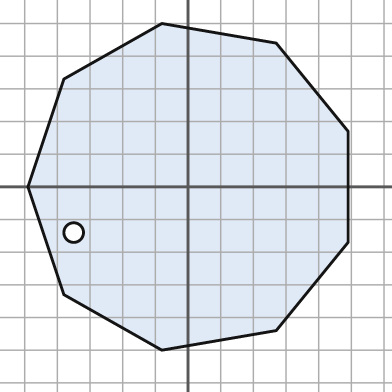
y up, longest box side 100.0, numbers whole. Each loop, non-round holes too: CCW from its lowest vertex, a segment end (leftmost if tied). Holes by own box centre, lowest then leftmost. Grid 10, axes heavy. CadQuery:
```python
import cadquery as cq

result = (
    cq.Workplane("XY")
    .moveTo(-8.0, -50.0)
    .lineTo(27.0, -44.0)
    .lineTo(49.0, -17.0)
    .lineTo(49.0, 17.0)
    .lineTo(27.0, 44.0)
    .lineTo(-8.0, 50.0)
    .lineTo(-38.0, 33.0)
    .lineTo(-49.0, 0.0)
    .lineTo(-38.0, -33.0)
    .close()
    .moveTo(-35.0, -14.0)
    .circle(3.0)
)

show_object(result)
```